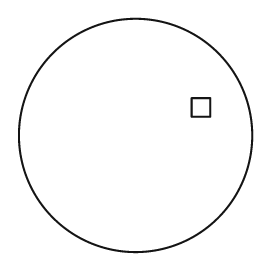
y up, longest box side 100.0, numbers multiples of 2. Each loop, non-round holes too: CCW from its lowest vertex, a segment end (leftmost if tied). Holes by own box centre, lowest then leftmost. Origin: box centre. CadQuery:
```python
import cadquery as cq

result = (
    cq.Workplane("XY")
    .moveTo(0.0, 0.0)
    .circle(50.0)
    .moveTo(24.0, 8.0)
    .lineTo(32.0, 8.0)
    .lineTo(32.0, 16.0)
    .lineTo(24.0, 16.0)
    .close()
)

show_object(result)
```